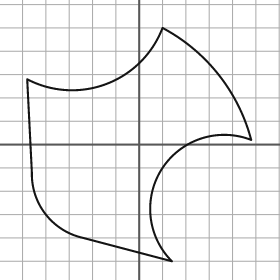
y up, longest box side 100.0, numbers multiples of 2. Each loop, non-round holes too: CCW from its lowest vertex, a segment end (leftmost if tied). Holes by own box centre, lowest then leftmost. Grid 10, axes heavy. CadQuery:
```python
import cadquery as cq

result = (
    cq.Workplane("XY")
    .moveTo(14.0, -50.0)
    .threePointArc((10.0, -10.0), (48.0, 2.0))
    .threePointArc((34.0, 30.0), (10.0, 50.0))
    .threePointArc((-14.0, 26.0), (-48.0, 28.0))
    .lineTo(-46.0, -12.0)
    .threePointArc((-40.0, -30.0), (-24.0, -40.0))
    .close()
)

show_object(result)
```